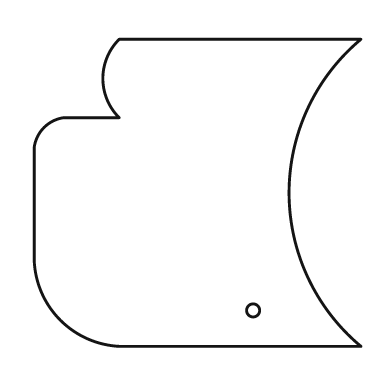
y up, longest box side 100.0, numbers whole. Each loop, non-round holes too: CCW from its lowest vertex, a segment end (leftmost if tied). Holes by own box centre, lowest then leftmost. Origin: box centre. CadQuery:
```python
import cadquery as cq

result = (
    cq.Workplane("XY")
    .moveTo(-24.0, -47.0)
    .lineTo(50.0, -47.0)
    .threePointArc((28.0, 0.0), (50.0, 47.0))
    .lineTo(-24.0, 47.0)
    .threePointArc((-29.0, 35.0), (-24.0, 23.0))
    .lineTo(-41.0, 23.0)
    .threePointArc((-47.0, 20.0), (-50.0, 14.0))
    .lineTo(-50.0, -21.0)
    .threePointArc((-42.0, -39.0), (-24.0, -47.0))
    .close()
    .moveTo(17.0, -36.0)
    .circle(2.0)
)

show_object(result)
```